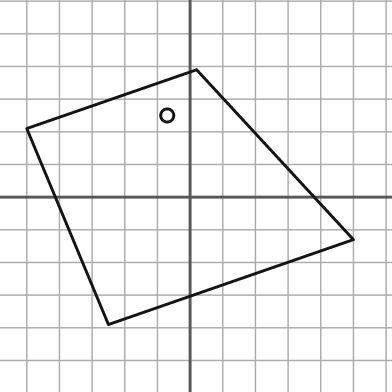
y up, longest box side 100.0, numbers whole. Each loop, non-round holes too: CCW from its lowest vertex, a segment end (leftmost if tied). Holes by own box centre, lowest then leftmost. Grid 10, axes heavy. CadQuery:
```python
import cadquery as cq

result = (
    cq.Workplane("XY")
    .moveTo(-25.0, -39.0)
    .lineTo(50.0, -13.0)
    .lineTo(2.0, 39.0)
    .lineTo(-50.0, 21.0)
    .close()
    .moveTo(-7.0, 25.0)
    .circle(2.0)
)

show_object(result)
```